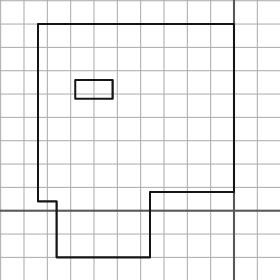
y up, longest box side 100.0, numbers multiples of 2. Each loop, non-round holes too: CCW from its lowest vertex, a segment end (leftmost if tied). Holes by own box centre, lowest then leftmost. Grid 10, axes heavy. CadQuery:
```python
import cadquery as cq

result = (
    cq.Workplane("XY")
    .moveTo(-76.0, -20.0)
    .lineTo(-36.0, -20.0)
    .lineTo(-36.0, 8.0)
    .lineTo(0.0, 8.0)
    .lineTo(0.0, 80.0)
    .lineTo(-84.0, 80.0)
    .lineTo(-84.0, 4.0)
    .lineTo(-76.0, 4.0)
    .close()
    .moveTo(-68.0, 48.0)
    .lineTo(-52.0, 48.0)
    .lineTo(-52.0, 56.0)
    .lineTo(-68.0, 56.0)
    .close()
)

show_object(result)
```